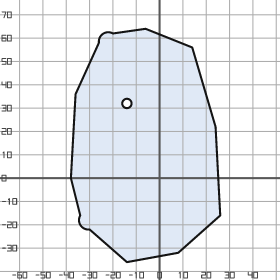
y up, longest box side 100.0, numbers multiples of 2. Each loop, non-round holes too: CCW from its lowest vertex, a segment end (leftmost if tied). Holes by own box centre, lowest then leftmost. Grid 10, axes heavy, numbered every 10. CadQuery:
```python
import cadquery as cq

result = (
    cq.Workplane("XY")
    .moveTo(-14.0, -36.0)
    .lineTo(8.0, -32.0)
    .lineTo(26.0, -16.0)
    .lineTo(24.0, 22.0)
    .lineTo(14.0, 56.0)
    .lineTo(-6.0, 64.0)
    .lineTo(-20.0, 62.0)
    .threePointArc((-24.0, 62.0), (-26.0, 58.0))
    .lineTo(-36.0, 36.0)
    .lineTo(-38.0, 0.0)
    .lineTo(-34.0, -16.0)
    .threePointArc((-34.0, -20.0), (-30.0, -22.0))
    .close()
    .moveTo(-14.0, 32.0)
    .circle(2.0)
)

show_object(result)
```